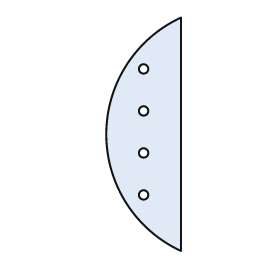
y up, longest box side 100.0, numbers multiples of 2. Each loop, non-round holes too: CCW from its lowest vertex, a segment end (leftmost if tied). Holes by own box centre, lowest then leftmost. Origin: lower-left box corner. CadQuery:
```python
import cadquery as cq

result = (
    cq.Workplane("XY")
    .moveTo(32.0, 0.0)
    .lineTo(32.0, 100.0)
    .threePointArc((0.0, 50.0), (32.0, 0.0))
    .close()
    .moveTo(16.0, 24.0)
    .circle(2.0)
    .moveTo(16.0, 42.0)
    .circle(2.0)
    .moveTo(16.0, 60.0)
    .circle(2.0)
    .moveTo(16.0, 78.0)
    .circle(2.0)
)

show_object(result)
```